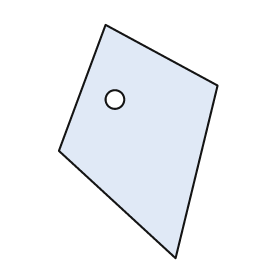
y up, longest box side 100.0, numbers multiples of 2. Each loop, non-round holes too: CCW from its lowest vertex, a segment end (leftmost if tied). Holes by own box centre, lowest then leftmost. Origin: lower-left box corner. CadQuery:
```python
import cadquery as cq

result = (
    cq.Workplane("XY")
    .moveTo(50.0, 0.0)
    .lineTo(68.0, 74.0)
    .lineTo(20.0, 100.0)
    .lineTo(0.0, 46.0)
    .close()
    .moveTo(24.0, 68.0)
    .circle(4.0)
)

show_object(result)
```